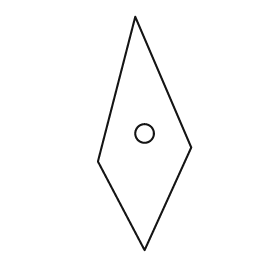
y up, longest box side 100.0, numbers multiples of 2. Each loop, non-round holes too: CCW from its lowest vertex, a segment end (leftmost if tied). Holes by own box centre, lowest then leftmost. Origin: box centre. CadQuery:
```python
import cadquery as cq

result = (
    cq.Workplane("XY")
    .moveTo(0.0, -50.0)
    .lineTo(20.0, -6.0)
    .lineTo(-4.0, 50.0)
    .lineTo(-20.0, -12.0)
    .close()
    .moveTo(0.0, 0.0)
    .circle(4.0)
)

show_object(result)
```